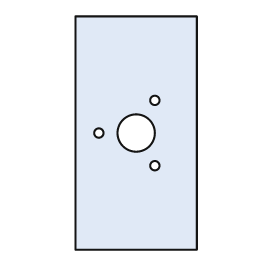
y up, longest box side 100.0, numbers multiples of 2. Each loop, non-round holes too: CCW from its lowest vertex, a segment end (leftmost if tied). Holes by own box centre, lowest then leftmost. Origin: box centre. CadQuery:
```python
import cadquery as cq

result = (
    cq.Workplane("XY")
    .moveTo(-26.0, -50.0)
    .lineTo(26.0, -50.0)
    .lineTo(26.0, 50.0)
    .lineTo(-26.0, 50.0)
    .close()
    .moveTo(8.0, -14.0)
    .circle(2.0)
    .moveTo(-16.0, 0.0)
    .circle(2.0)
    .moveTo(0.0, 0.0)
    .circle(8.0)
    .moveTo(8.0, 14.0)
    .circle(2.0)
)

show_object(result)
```